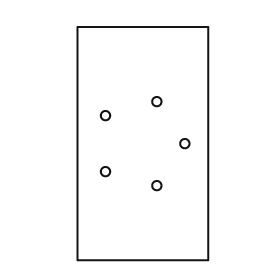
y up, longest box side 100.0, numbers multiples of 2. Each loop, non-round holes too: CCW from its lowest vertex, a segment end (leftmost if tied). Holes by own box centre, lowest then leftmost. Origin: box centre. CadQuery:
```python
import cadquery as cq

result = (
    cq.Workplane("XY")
    .moveTo(-28.0, -50.0)
    .lineTo(28.0, -50.0)
    .lineTo(28.0, 50.0)
    .lineTo(-28.0, 50.0)
    .close()
    .moveTo(6.0, -18.0)
    .circle(2.0)
    .moveTo(-16.0, -12.0)
    .circle(2.0)
    .moveTo(18.0, 0.0)
    .circle(2.0)
    .moveTo(-16.0, 12.0)
    .circle(2.0)
    .moveTo(6.0, 18.0)
    .circle(2.0)
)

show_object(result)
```